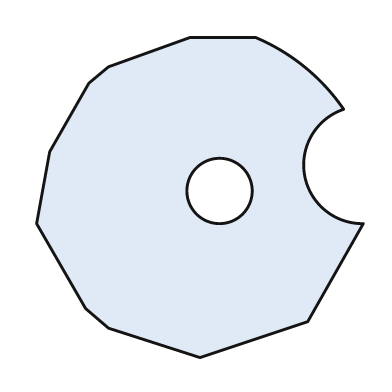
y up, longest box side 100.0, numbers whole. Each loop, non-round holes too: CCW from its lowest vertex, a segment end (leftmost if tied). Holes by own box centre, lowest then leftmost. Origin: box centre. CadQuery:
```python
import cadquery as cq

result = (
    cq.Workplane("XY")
    .moveTo(0.0, -49.0)
    .lineTo(33.0, -38.0)
    .lineTo(50.0, -8.0)
    .threePointArc((32.0, 7.0), (44.0, 27.0))
    .threePointArc((32.0, 40.0), (17.0, 49.0))
    .lineTo(-3.0, 49.0)
    .lineTo(-28.0, 40.0)
    .lineTo(-34.0, 35.0)
    .lineTo(-46.0, 14.0)
    .lineTo(-50.0, -8.0)
    .lineTo(-35.0, -34.0)
    .lineTo(-28.0, -40.0)
    .close()
    .moveTo(6.0, 2.0)
    .circle(10.0)
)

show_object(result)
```